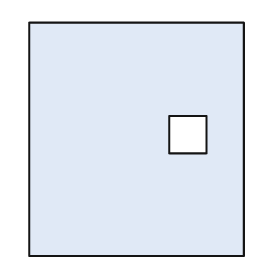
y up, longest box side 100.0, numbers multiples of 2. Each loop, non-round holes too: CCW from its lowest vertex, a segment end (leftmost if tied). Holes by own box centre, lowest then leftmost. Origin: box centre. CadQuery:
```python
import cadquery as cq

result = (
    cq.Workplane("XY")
    .moveTo(-46.0, -50.0)
    .lineTo(46.0, -50.0)
    .lineTo(46.0, 50.0)
    .lineTo(-46.0, 50.0)
    .close()
    .moveTo(14.0, -6.0)
    .lineTo(30.0, -6.0)
    .lineTo(30.0, 10.0)
    .lineTo(14.0, 10.0)
    .close()
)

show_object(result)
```